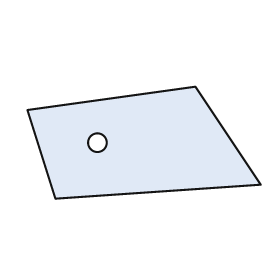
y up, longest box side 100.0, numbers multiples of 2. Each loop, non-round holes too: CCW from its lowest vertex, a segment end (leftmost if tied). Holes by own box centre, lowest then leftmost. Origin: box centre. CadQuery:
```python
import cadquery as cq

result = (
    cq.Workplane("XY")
    .moveTo(-38.0, -24.0)
    .lineTo(50.0, -18.0)
    .lineTo(22.0, 24.0)
    .lineTo(-50.0, 14.0)
    .close()
    .moveTo(-20.0, 0.0)
    .circle(4.0)
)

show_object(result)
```